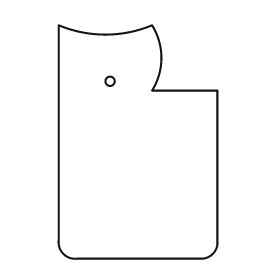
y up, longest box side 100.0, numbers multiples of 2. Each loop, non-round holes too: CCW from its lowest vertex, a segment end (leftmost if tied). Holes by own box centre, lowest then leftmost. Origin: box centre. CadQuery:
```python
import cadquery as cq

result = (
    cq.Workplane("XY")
    .moveTo(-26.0, -50.0)
    .lineTo(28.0, -50.0)
    .threePointArc((32.0, -48.0), (34.0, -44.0))
    .lineTo(34.0, 22.0)
    .lineTo(6.0, 22.0)
    .threePointArc((10.0, 36.0), (6.0, 50.0))
    .threePointArc((-14.0, 46.0), (-34.0, 50.0))
    .lineTo(-34.0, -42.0)
    .threePointArc((-32.0, -48.0), (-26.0, -50.0))
    .close()
    .moveTo(-12.0, 26.0)
    .circle(2.0)
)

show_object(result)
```